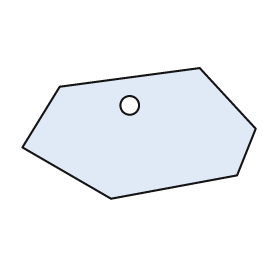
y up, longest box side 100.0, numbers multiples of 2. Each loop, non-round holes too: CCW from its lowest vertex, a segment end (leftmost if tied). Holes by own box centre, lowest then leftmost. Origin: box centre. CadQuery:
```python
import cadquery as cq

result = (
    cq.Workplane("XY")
    .moveTo(-12.0, -28.0)
    .lineTo(42.0, -18.0)
    .lineTo(50.0, 2.0)
    .lineTo(26.0, 28.0)
    .lineTo(-34.0, 20.0)
    .lineTo(-50.0, -6.0)
    .close()
    .moveTo(-4.0, 12.0)
    .circle(4.0)
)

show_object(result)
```